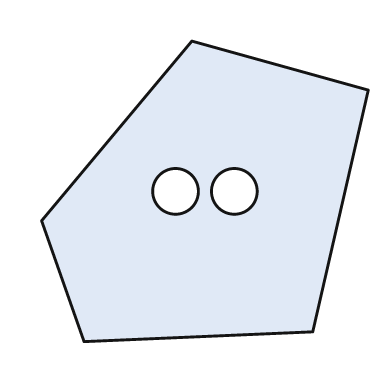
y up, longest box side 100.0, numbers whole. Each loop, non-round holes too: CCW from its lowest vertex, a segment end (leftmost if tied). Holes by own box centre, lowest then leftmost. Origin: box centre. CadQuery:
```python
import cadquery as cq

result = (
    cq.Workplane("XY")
    .moveTo(-37.0, -46.0)
    .lineTo(33.0, -43.0)
    .lineTo(50.0, 31.0)
    .lineTo(-4.0, 46.0)
    .lineTo(-50.0, -9.0)
    .close()
    .moveTo(-9.0, 0.0)
    .circle(7.0)
    .moveTo(9.0, 0.0)
    .circle(7.0)
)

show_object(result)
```